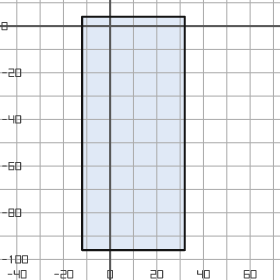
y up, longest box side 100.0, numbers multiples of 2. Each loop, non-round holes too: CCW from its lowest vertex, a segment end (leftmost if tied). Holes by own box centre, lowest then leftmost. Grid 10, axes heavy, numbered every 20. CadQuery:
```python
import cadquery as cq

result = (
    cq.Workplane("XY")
    .moveTo(-12.0, -96.0)
    .lineTo(32.0, -96.0)
    .lineTo(32.0, 4.0)
    .lineTo(-12.0, 4.0)
    .close()
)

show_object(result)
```